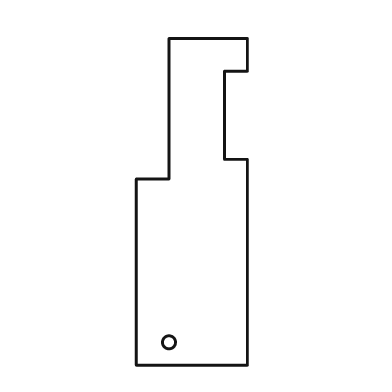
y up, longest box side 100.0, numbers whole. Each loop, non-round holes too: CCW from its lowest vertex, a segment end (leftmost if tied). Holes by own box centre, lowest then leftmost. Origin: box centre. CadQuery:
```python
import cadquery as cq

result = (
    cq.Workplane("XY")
    .moveTo(-17.0, -50.0)
    .lineTo(17.0, -50.0)
    .lineTo(17.0, 13.0)
    .lineTo(10.0, 13.0)
    .lineTo(10.0, 40.0)
    .lineTo(17.0, 40.0)
    .lineTo(17.0, 50.0)
    .lineTo(-7.0, 50.0)
    .lineTo(-7.0, 7.0)
    .lineTo(-17.0, 7.0)
    .close()
    .moveTo(-7.0, -43.0)
    .circle(2.0)
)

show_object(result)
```